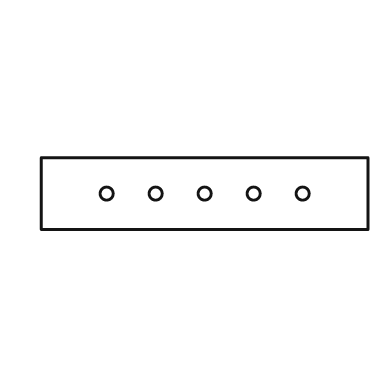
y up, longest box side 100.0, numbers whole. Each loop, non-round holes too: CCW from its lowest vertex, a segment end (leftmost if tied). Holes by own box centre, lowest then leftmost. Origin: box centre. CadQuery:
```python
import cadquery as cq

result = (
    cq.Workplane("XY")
    .moveTo(-50.0, -11.0)
    .lineTo(50.0, -11.0)
    .lineTo(50.0, 11.0)
    .lineTo(-50.0, 11.0)
    .close()
    .moveTo(-30.0, 0.0)
    .circle(2.0)
    .moveTo(-15.0, 0.0)
    .circle(2.0)
    .moveTo(0.0, 0.0)
    .circle(2.0)
    .moveTo(15.0, 0.0)
    .circle(2.0)
    .moveTo(30.0, 0.0)
    .circle(2.0)
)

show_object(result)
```